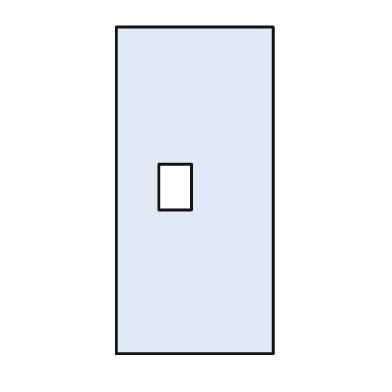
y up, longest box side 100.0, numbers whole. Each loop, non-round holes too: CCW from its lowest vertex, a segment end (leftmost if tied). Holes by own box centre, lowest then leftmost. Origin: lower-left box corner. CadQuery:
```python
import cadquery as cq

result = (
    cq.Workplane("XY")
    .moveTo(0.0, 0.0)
    .lineTo(48.0, 0.0)
    .lineTo(48.0, 100.0)
    .lineTo(0.0, 100.0)
    .close()
    .moveTo(13.0, 44.0)
    .lineTo(23.0, 44.0)
    .lineTo(23.0, 58.0)
    .lineTo(13.0, 58.0)
    .close()
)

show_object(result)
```